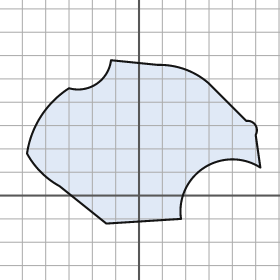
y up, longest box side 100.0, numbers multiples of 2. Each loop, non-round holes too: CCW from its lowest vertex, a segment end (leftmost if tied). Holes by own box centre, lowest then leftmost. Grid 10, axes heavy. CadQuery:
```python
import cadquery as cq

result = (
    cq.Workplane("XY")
    .moveTo(-14.0, -12.0)
    .lineTo(18.0, -10.0)
    .threePointArc((28.0, 12.0), (52.0, 12.0))
    .lineTo(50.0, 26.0)
    .threePointArc((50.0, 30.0), (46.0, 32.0))
    .lineTo(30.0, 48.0)
    .threePointArc((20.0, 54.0), (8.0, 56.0))
    .lineTo(-12.0, 58.0)
    .threePointArc((-18.0, 48.0), (-30.0, 46.0))
    .threePointArc((-42.0, 34.0), (-48.0, 18.0))
    .threePointArc((-42.0, 10.0), (-34.0, 4.0))
    .close()
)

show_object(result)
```